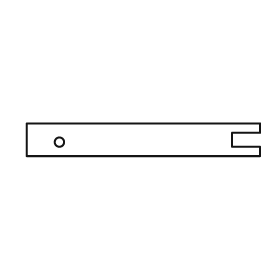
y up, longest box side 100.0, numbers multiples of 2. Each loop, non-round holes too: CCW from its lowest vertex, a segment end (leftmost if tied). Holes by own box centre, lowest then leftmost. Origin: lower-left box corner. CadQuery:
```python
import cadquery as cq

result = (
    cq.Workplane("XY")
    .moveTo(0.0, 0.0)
    .lineTo(100.0, 0.0)
    .lineTo(100.0, 4.0)
    .lineTo(88.0, 4.0)
    .lineTo(88.0, 10.0)
    .lineTo(100.0, 10.0)
    .lineTo(100.0, 14.0)
    .lineTo(0.0, 14.0)
    .close()
    .moveTo(14.0, 6.0)
    .circle(2.0)
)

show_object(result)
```